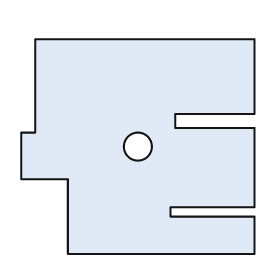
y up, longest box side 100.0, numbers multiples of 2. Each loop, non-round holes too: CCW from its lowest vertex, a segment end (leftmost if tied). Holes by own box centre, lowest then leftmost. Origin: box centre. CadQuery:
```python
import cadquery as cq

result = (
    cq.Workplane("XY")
    .moveTo(-30.0, -46.0)
    .lineTo(50.0, -46.0)
    .lineTo(50.0, -30.0)
    .lineTo(14.0, -30.0)
    .lineTo(14.0, -26.0)
    .lineTo(50.0, -26.0)
    .lineTo(50.0, 8.0)
    .lineTo(16.0, 8.0)
    .lineTo(16.0, 14.0)
    .lineTo(50.0, 14.0)
    .lineTo(50.0, 46.0)
    .lineTo(-44.0, 46.0)
    .lineTo(-44.0, 6.0)
    .lineTo(-50.0, 6.0)
    .lineTo(-50.0, -14.0)
    .lineTo(-30.0, -14.0)
    .close()
    .moveTo(0.0, 0.0)
    .circle(6.0)
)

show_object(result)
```